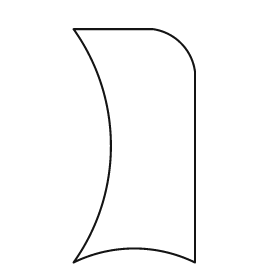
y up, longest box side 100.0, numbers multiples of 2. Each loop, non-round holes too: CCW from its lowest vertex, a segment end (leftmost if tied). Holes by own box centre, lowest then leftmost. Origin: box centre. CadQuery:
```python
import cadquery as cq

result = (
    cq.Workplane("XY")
    .moveTo(-26.0, -50.0)
    .threePointArc((0.0, -44.0), (26.0, -50.0))
    .lineTo(26.0, 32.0)
    .threePointArc((20.0, 44.0), (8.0, 50.0))
    .lineTo(-26.0, 50.0)
    .threePointArc((-10.0, 0.0), (-26.0, -50.0))
    .close()
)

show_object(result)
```